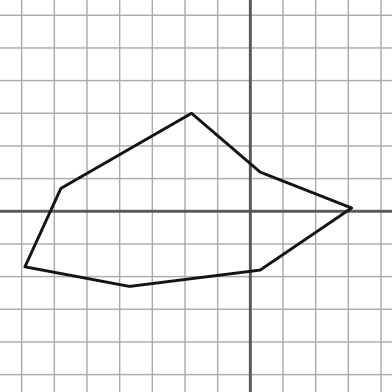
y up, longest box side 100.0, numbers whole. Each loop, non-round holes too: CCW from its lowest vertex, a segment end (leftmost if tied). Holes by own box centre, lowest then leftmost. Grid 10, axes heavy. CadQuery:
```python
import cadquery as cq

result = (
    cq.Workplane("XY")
    .moveTo(-37.0, -23.0)
    .lineTo(3.0, -18.0)
    .lineTo(31.0, 1.0)
    .lineTo(3.0, 12.0)
    .lineTo(-18.0, 30.0)
    .lineTo(-58.0, 7.0)
    .lineTo(-69.0, -17.0)
    .close()
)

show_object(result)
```